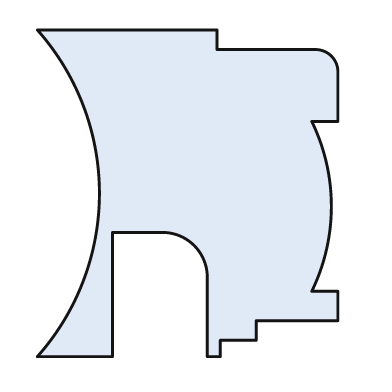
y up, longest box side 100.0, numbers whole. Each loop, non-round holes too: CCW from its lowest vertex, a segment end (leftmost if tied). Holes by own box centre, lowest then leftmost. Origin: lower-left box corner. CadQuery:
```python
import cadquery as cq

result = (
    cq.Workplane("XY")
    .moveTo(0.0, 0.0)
    .lineTo(23.0, 0.0)
    .lineTo(23.0, 38.0)
    .lineTo(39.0, 38.0)
    .threePointArc((48.0, 34.0), (52.0, 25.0))
    .lineTo(52.0, 0.0)
    .lineTo(56.0, 0.0)
    .lineTo(56.0, 5.0)
    .lineTo(67.0, 5.0)
    .lineTo(67.0, 11.0)
    .lineTo(92.0, 11.0)
    .lineTo(92.0, 20.0)
    .lineTo(84.0, 20.0)
    .threePointArc((90.0, 46.0), (84.0, 72.0))
    .lineTo(92.0, 72.0)
    .lineTo(92.0, 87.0)
    .threePointArc((90.0, 92.0), (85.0, 94.0))
    .lineTo(55.0, 94.0)
    .lineTo(55.0, 100.0)
    .lineTo(0.0, 100.0)
    .threePointArc((19.0, 50.0), (0.0, 0.0))
    .close()
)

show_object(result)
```